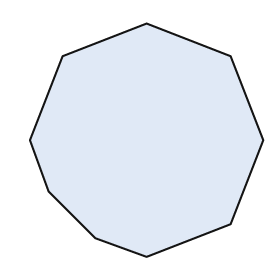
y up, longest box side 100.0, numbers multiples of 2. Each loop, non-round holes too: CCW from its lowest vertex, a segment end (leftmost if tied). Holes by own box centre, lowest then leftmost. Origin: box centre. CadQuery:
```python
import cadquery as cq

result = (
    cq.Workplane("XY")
    .moveTo(0.0, -50.0)
    .lineTo(36.0, -36.0)
    .lineTo(50.0, 0.0)
    .lineTo(36.0, 36.0)
    .lineTo(0.0, 50.0)
    .lineTo(-36.0, 36.0)
    .lineTo(-50.0, 0.0)
    .lineTo(-42.0, -22.0)
    .lineTo(-22.0, -42.0)
    .close()
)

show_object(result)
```